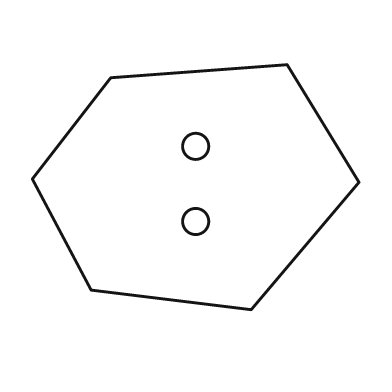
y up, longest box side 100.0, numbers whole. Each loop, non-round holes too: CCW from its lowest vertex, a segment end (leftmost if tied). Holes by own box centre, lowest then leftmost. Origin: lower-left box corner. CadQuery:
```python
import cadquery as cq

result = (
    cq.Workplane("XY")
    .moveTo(67.0, 0.0)
    .lineTo(100.0, 39.0)
    .lineTo(78.0, 75.0)
    .lineTo(24.0, 71.0)
    .lineTo(0.0, 40.0)
    .lineTo(18.0, 6.0)
    .close()
    .moveTo(50.0, 27.0)
    .circle(4.0)
    .moveTo(50.0, 50.0)
    .circle(4.0)
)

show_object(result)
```